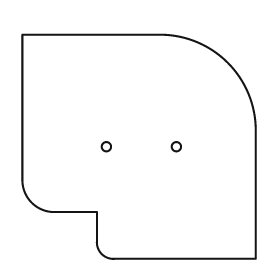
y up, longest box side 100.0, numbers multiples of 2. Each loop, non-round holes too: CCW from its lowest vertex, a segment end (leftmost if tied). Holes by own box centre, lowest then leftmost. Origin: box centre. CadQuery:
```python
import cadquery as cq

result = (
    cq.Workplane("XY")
    .moveTo(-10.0, -48.0)
    .lineTo(50.0, -48.0)
    .lineTo(50.0, 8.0)
    .threePointArc((38.0, 36.0), (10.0, 48.0))
    .lineTo(-50.0, 48.0)
    .lineTo(-50.0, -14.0)
    .threePointArc((-46.0, -24.0), (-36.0, -28.0))
    .lineTo(-18.0, -28.0)
    .lineTo(-18.0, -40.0)
    .threePointArc((-16.0, -46.0), (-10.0, -48.0))
    .close()
    .moveTo(-14.0, 0.0)
    .circle(2.0)
    .moveTo(16.0, 0.0)
    .circle(2.0)
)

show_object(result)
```